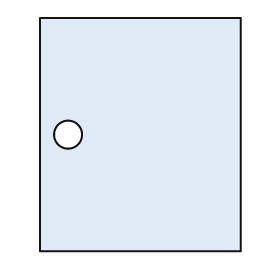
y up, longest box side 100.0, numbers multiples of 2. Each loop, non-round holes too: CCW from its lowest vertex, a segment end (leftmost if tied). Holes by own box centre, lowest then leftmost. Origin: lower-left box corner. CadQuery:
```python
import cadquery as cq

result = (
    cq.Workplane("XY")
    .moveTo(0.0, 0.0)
    .lineTo(86.0, 0.0)
    .lineTo(86.0, 100.0)
    .lineTo(0.0, 100.0)
    .close()
    .moveTo(12.0, 50.0)
    .circle(6.0)
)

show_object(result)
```